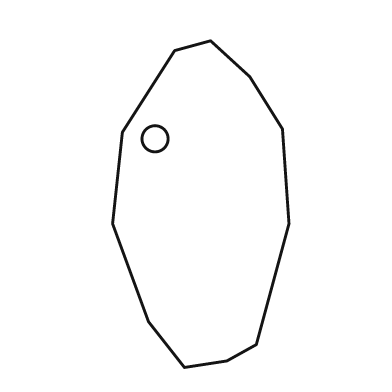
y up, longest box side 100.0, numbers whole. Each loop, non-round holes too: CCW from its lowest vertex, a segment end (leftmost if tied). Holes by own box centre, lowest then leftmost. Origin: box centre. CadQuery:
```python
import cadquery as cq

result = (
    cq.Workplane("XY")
    .moveTo(-5.0, -50.0)
    .lineTo(8.0, -48.0)
    .lineTo(17.0, -43.0)
    .lineTo(27.0, -6.0)
    .lineTo(25.0, 23.0)
    .lineTo(15.0, 39.0)
    .lineTo(3.0, 50.0)
    .lineTo(-8.0, 47.0)
    .lineTo(-24.0, 22.0)
    .lineTo(-27.0, -6.0)
    .lineTo(-16.0, -36.0)
    .close()
    .moveTo(-14.0, 20.0)
    .circle(4.0)
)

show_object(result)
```